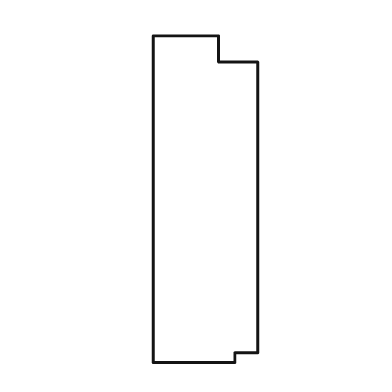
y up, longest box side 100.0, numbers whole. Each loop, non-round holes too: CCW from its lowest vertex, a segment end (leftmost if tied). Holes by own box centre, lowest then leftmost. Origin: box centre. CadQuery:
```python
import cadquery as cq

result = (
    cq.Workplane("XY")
    .moveTo(-16.0, -50.0)
    .lineTo(9.0, -50.0)
    .lineTo(9.0, -47.0)
    .lineTo(16.0, -47.0)
    .lineTo(16.0, 42.0)
    .lineTo(4.0, 42.0)
    .lineTo(4.0, 50.0)
    .lineTo(-16.0, 50.0)
    .close()
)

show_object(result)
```